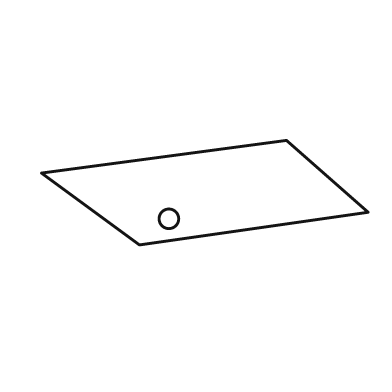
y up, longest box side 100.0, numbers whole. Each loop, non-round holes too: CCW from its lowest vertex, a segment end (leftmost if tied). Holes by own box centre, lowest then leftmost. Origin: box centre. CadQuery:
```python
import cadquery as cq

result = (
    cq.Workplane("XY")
    .moveTo(-20.0, -16.0)
    .lineTo(50.0, -6.0)
    .lineTo(25.0, 16.0)
    .lineTo(-50.0, 6.0)
    .close()
    .moveTo(-11.0, -8.0)
    .circle(3.0)
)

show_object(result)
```